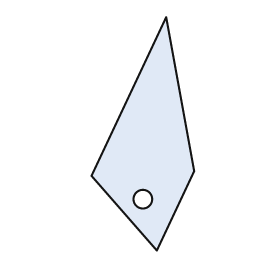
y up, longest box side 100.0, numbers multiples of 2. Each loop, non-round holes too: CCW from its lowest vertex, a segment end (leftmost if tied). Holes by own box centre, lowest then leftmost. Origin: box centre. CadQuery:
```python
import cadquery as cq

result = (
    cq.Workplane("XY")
    .moveTo(6.0, -50.0)
    .lineTo(22.0, -16.0)
    .lineTo(10.0, 50.0)
    .lineTo(-22.0, -18.0)
    .close()
    .moveTo(0.0, -28.0)
    .circle(4.0)
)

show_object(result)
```